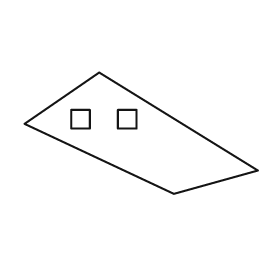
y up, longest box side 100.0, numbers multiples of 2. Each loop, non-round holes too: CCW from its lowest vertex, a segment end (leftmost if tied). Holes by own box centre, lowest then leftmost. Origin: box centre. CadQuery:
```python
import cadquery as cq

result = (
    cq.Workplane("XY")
    .moveTo(14.0, -26.0)
    .lineTo(50.0, -16.0)
    .lineTo(-18.0, 26.0)
    .lineTo(-50.0, 4.0)
    .close()
    .moveTo(-30.0, 2.0)
    .lineTo(-22.0, 2.0)
    .lineTo(-22.0, 10.0)
    .lineTo(-30.0, 10.0)
    .close()
    .moveTo(-10.0, 2.0)
    .lineTo(-2.0, 2.0)
    .lineTo(-2.0, 10.0)
    .lineTo(-10.0, 10.0)
    .close()
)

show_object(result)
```